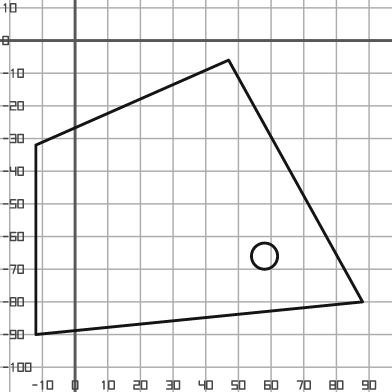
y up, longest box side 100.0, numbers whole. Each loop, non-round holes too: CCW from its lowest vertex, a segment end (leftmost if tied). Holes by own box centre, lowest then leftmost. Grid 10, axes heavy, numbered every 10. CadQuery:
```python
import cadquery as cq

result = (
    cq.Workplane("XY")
    .moveTo(-12.0, -90.0)
    .lineTo(88.0, -80.0)
    .lineTo(47.0, -6.0)
    .lineTo(-12.0, -32.0)
    .close()
    .moveTo(58.0, -66.0)
    .circle(4.0)
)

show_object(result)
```